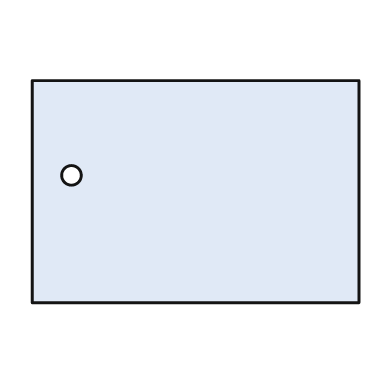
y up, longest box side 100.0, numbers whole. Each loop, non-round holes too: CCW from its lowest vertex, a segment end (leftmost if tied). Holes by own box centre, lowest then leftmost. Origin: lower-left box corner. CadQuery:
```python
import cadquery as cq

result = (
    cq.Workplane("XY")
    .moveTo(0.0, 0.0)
    .lineTo(100.0, 0.0)
    .lineTo(100.0, 68.0)
    .lineTo(0.0, 68.0)
    .close()
    .moveTo(12.0, 39.0)
    .circle(3.0)
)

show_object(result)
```